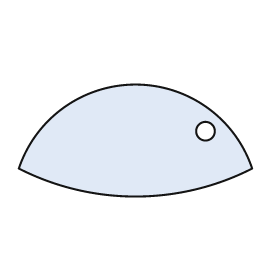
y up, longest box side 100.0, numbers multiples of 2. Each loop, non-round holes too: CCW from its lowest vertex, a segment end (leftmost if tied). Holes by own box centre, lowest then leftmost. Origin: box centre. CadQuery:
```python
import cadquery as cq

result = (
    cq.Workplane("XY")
    .moveTo(-50.0, -12.0)
    .threePointArc((0.0, -24.0), (50.0, -12.0))
    .threePointArc((0.0, 24.0), (-50.0, -12.0))
    .close()
    .moveTo(30.0, 4.0)
    .circle(4.0)
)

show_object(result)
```